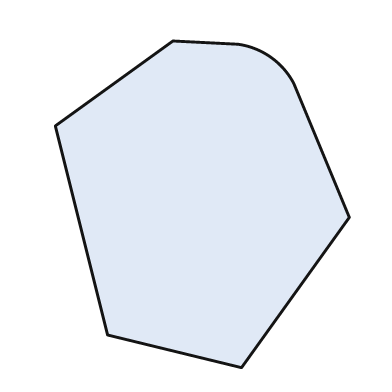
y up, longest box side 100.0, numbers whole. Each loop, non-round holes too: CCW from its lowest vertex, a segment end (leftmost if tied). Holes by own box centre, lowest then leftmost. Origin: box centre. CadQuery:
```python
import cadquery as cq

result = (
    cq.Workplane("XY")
    .moveTo(12.0, -50.0)
    .lineTo(45.0, -4.0)
    .lineTo(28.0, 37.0)
    .threePointArc((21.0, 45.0), (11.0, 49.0))
    .lineTo(-9.0, 50.0)
    .lineTo(-45.0, 24.0)
    .lineTo(-29.0, -40.0)
    .close()
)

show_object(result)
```